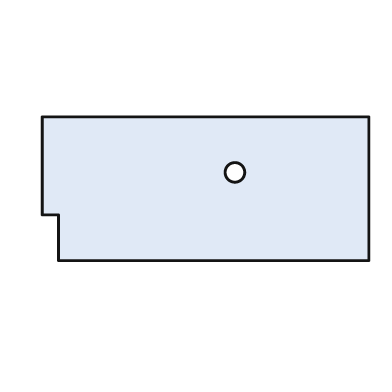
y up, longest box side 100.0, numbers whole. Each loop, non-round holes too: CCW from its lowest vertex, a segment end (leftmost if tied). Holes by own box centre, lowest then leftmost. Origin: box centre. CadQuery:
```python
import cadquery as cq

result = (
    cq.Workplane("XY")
    .moveTo(-45.0, -22.0)
    .lineTo(50.0, -22.0)
    .lineTo(50.0, 22.0)
    .lineTo(-50.0, 22.0)
    .lineTo(-50.0, -8.0)
    .lineTo(-45.0, -8.0)
    .close()
    .moveTo(9.0, 5.0)
    .circle(3.0)
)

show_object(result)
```